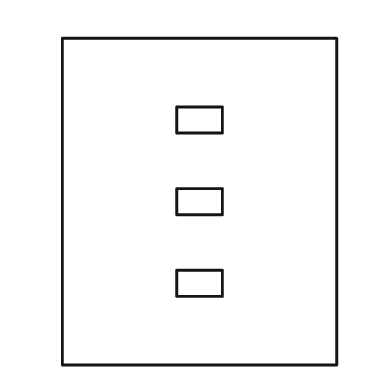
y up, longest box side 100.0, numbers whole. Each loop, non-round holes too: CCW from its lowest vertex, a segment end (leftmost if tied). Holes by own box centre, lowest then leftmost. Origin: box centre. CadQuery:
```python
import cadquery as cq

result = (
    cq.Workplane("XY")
    .moveTo(-42.0, -50.0)
    .lineTo(42.0, -50.0)
    .lineTo(42.0, 50.0)
    .lineTo(-42.0, 50.0)
    .close()
    .moveTo(-7.0, -29.0)
    .lineTo(7.0, -29.0)
    .lineTo(7.0, -21.0)
    .lineTo(-7.0, -21.0)
    .close()
    .moveTo(-7.0, -4.0)
    .lineTo(7.0, -4.0)
    .lineTo(7.0, 4.0)
    .lineTo(-7.0, 4.0)
    .close()
    .moveTo(-7.0, 21.0)
    .lineTo(7.0, 21.0)
    .lineTo(7.0, 29.0)
    .lineTo(-7.0, 29.0)
    .close()
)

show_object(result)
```